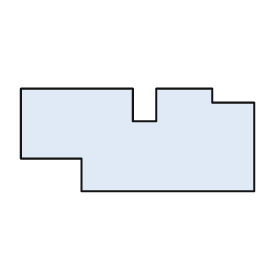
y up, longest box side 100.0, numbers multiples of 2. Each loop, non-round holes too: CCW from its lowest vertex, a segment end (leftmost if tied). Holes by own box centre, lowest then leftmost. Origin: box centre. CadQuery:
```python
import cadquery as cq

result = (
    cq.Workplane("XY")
    .moveTo(-24.0, -22.0)
    .lineTo(50.0, -22.0)
    .lineTo(50.0, 16.0)
    .lineTo(32.0, 16.0)
    .lineTo(32.0, 22.0)
    .lineTo(8.0, 22.0)
    .lineTo(8.0, 8.0)
    .lineTo(-2.0, 8.0)
    .lineTo(-2.0, 22.0)
    .lineTo(-50.0, 22.0)
    .lineTo(-50.0, -8.0)
    .lineTo(-24.0, -8.0)
    .close()
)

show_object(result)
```